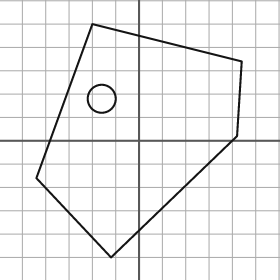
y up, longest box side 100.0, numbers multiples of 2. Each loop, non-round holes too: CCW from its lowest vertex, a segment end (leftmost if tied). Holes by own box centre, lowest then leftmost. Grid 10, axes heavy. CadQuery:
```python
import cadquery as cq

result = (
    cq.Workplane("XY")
    .moveTo(-12.0, -50.0)
    .lineTo(42.0, 2.0)
    .lineTo(44.0, 34.0)
    .lineTo(-20.0, 50.0)
    .lineTo(-44.0, -16.0)
    .close()
    .moveTo(-16.0, 18.0)
    .circle(6.0)
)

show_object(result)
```